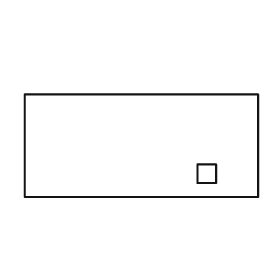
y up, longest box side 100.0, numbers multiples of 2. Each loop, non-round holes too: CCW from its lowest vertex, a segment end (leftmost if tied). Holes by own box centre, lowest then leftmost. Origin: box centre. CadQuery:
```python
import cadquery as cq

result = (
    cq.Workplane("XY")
    .moveTo(-50.0, -22.0)
    .lineTo(50.0, -22.0)
    .lineTo(50.0, 22.0)
    .lineTo(-50.0, 22.0)
    .close()
    .moveTo(24.0, -16.0)
    .lineTo(32.0, -16.0)
    .lineTo(32.0, -8.0)
    .lineTo(24.0, -8.0)
    .close()
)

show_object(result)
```